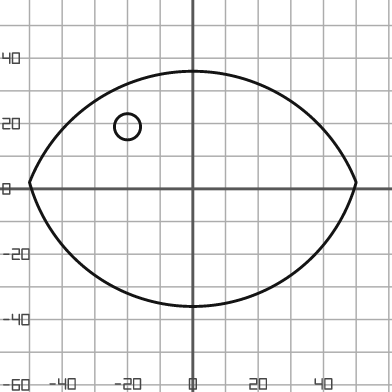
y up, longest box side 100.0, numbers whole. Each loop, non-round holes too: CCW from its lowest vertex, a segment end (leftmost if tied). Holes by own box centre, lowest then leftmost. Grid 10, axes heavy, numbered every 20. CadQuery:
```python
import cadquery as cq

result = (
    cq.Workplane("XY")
    .moveTo(-50.0, 2.0)
    .threePointArc((0.0, -36.0), (50.0, 2.0))
    .threePointArc((0.0, 36.0), (-50.0, 2.0))
    .close()
    .moveTo(-20.0, 19.0)
    .circle(4.0)
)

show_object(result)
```